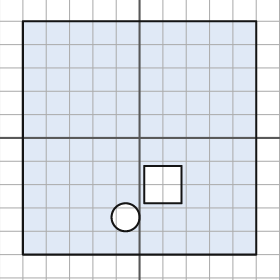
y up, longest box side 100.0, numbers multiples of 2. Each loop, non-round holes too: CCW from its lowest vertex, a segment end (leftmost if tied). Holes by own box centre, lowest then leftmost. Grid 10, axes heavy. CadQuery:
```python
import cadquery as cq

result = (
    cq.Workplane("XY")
    .moveTo(-50.0, -50.0)
    .lineTo(50.0, -50.0)
    .lineTo(50.0, 50.0)
    .lineTo(-50.0, 50.0)
    .close()
    .moveTo(-6.0, -34.0)
    .circle(6.0)
    .moveTo(2.0, -28.0)
    .lineTo(18.0, -28.0)
    .lineTo(18.0, -12.0)
    .lineTo(2.0, -12.0)
    .close()
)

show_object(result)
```